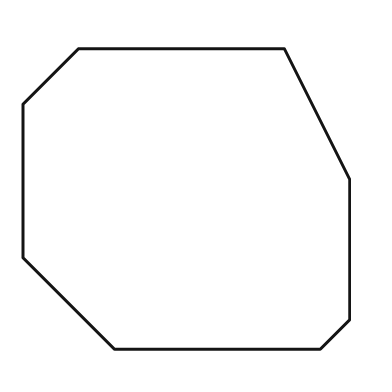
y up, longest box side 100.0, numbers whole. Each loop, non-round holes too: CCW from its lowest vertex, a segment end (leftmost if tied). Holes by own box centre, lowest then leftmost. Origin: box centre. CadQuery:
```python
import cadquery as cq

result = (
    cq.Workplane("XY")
    .moveTo(-22.0, -46.0)
    .lineTo(41.0, -46.0)
    .lineTo(50.0, -37.0)
    .lineTo(50.0, 6.0)
    .lineTo(30.0, 46.0)
    .lineTo(-33.0, 46.0)
    .lineTo(-50.0, 29.0)
    .lineTo(-50.0, -18.0)
    .close()
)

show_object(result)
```